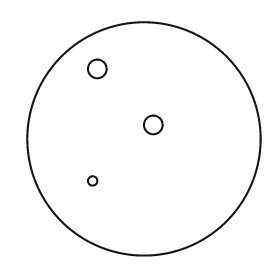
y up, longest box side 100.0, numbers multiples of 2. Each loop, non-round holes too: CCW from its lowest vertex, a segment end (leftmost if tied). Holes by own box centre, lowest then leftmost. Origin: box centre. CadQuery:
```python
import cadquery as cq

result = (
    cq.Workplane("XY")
    .moveTo(0.0, 0.0)
    .circle(50.0)
    .moveTo(-22.0, -18.0)
    .circle(2.0)
    .moveTo(4.0, 6.0)
    .circle(4.0)
    .moveTo(-20.0, 30.0)
    .circle(4.0)
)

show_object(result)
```